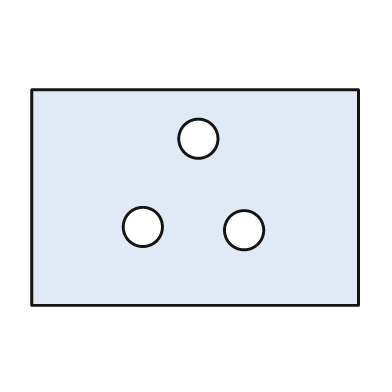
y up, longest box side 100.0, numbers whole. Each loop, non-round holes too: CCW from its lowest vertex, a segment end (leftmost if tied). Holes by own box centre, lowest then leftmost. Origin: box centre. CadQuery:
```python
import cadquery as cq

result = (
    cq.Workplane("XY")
    .moveTo(-50.0, -33.0)
    .lineTo(50.0, -33.0)
    .lineTo(50.0, 33.0)
    .lineTo(-50.0, 33.0)
    .close()
    .moveTo(15.0, -10.0)
    .circle(6.0)
    .moveTo(-16.0, -9.0)
    .circle(6.0)
    .moveTo(1.0, 18.0)
    .circle(6.0)
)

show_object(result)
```